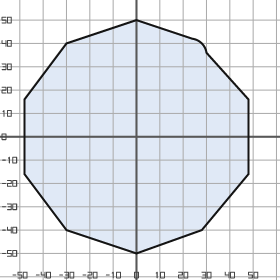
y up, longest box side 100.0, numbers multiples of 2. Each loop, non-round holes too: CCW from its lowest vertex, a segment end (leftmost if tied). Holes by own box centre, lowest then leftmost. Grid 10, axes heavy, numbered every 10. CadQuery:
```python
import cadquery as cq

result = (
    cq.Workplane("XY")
    .moveTo(0.0, -50.0)
    .lineTo(28.0, -40.0)
    .lineTo(48.0, -16.0)
    .lineTo(48.0, 16.0)
    .lineTo(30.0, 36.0)
    .threePointArc((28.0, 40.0), (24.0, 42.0))
    .lineTo(0.0, 50.0)
    .lineTo(-30.0, 40.0)
    .lineTo(-48.0, 16.0)
    .lineTo(-48.0, -16.0)
    .lineTo(-30.0, -40.0)
    .close()
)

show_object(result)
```